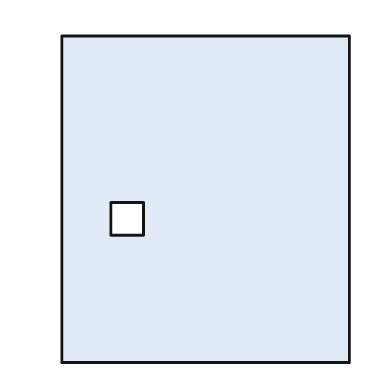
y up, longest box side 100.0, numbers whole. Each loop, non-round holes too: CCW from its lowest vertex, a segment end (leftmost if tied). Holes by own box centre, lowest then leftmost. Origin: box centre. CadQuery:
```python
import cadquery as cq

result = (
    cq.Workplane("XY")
    .moveTo(-44.0, -50.0)
    .lineTo(44.0, -50.0)
    .lineTo(44.0, 50.0)
    .lineTo(-44.0, 50.0)
    .close()
    .moveTo(-29.0, -11.0)
    .lineTo(-19.0, -11.0)
    .lineTo(-19.0, -1.0)
    .lineTo(-29.0, -1.0)
    .close()
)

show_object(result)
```